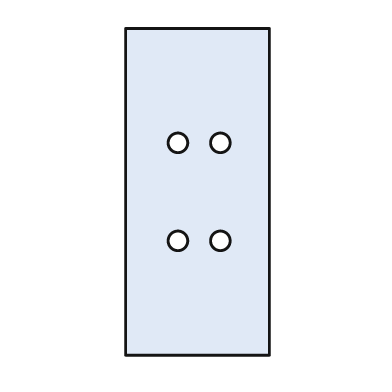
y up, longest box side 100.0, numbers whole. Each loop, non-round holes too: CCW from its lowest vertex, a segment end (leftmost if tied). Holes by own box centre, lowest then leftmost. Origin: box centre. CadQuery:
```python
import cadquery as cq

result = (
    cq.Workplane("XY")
    .moveTo(-22.0, -50.0)
    .lineTo(22.0, -50.0)
    .lineTo(22.0, 50.0)
    .lineTo(-22.0, 50.0)
    .close()
    .moveTo(-6.0, -15.0)
    .circle(3.0)
    .moveTo(7.0, -15.0)
    .circle(3.0)
    .moveTo(-6.0, 15.0)
    .circle(3.0)
    .moveTo(7.0, 15.0)
    .circle(3.0)
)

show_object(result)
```